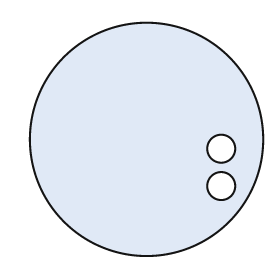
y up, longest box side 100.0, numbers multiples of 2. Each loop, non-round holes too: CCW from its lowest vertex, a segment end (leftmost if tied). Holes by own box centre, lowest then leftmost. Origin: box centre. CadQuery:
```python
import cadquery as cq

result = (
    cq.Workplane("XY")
    .moveTo(0.0, 0.0)
    .circle(50.0)
    .moveTo(32.0, -20.0)
    .circle(6.0)
    .moveTo(32.0, -4.0)
    .circle(6.0)
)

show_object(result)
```